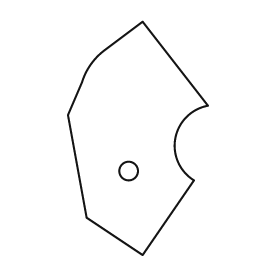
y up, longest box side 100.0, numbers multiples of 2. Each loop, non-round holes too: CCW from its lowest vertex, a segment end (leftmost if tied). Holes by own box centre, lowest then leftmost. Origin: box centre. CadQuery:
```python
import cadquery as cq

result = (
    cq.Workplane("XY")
    .moveTo(2.0, -50.0)
    .lineTo(24.0, -18.0)
    .threePointArc((16.0, 0.0), (30.0, 14.0))
    .lineTo(2.0, 50.0)
    .lineTo(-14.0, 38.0)
    .threePointArc((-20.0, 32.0), (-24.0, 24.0))
    .lineTo(-30.0, 10.0)
    .lineTo(-22.0, -34.0)
    .close()
    .moveTo(-4.0, -14.0)
    .circle(4.0)
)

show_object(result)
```